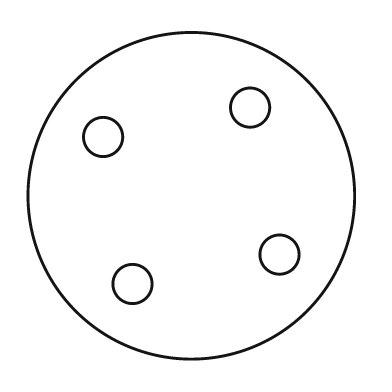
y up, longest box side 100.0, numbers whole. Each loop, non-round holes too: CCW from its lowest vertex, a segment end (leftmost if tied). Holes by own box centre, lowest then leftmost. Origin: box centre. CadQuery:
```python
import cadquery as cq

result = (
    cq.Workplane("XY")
    .moveTo(0.0, 0.0)
    .circle(50.0)
    .moveTo(-18.0, -27.0)
    .circle(6.0)
    .moveTo(27.0, -18.0)
    .circle(6.0)
    .moveTo(-27.0, 18.0)
    .circle(6.0)
    .moveTo(18.0, 27.0)
    .circle(6.0)
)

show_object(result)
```